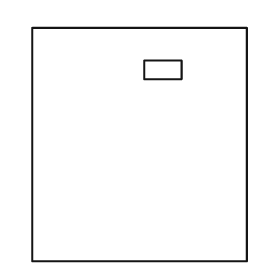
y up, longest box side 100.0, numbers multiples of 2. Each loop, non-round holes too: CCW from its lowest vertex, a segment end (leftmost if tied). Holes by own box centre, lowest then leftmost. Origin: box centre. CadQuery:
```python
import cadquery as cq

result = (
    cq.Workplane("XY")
    .moveTo(-46.0, -50.0)
    .lineTo(46.0, -50.0)
    .lineTo(46.0, 50.0)
    .lineTo(-46.0, 50.0)
    .close()
    .moveTo(2.0, 28.0)
    .lineTo(18.0, 28.0)
    .lineTo(18.0, 36.0)
    .lineTo(2.0, 36.0)
    .close()
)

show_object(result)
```